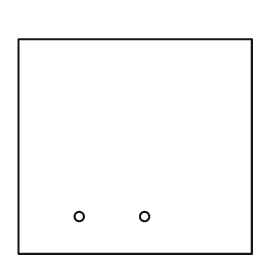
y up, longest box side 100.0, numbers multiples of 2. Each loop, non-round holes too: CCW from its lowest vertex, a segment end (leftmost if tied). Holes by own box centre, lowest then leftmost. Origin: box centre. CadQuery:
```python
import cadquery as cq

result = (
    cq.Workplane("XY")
    .moveTo(-50.0, -46.0)
    .lineTo(50.0, -46.0)
    .lineTo(50.0, 46.0)
    .lineTo(-50.0, 46.0)
    .close()
    .moveTo(-24.0, -30.0)
    .circle(2.0)
    .moveTo(4.0, -30.0)
    .circle(2.0)
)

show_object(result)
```